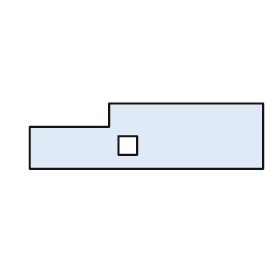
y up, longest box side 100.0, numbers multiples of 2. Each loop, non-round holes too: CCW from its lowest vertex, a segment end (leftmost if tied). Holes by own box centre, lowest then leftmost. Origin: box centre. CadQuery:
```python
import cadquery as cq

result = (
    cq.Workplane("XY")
    .moveTo(-50.0, -14.0)
    .lineTo(50.0, -14.0)
    .lineTo(50.0, 14.0)
    .lineTo(-16.0, 14.0)
    .lineTo(-16.0, 4.0)
    .lineTo(-50.0, 4.0)
    .close()
    .moveTo(-12.0, -8.0)
    .lineTo(-4.0, -8.0)
    .lineTo(-4.0, 0.0)
    .lineTo(-12.0, 0.0)
    .close()
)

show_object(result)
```